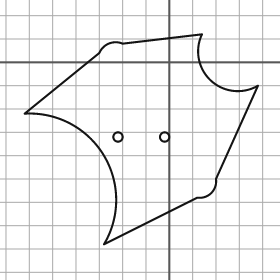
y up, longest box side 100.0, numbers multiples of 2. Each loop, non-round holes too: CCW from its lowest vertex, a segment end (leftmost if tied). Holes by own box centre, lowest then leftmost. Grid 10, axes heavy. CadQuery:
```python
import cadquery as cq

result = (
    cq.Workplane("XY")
    .moveTo(-28.0, -78.0)
    .lineTo(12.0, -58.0)
    .threePointArc((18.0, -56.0), (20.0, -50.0))
    .lineTo(38.0, -10.0)
    .threePointArc((18.0, -8.0), (14.0, 12.0))
    .lineTo(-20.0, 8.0)
    .threePointArc((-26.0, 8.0), (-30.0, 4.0))
    .lineTo(-62.0, -22.0)
    .threePointArc((-28.0, -40.0), (-28.0, -78.0))
    .close()
    .moveTo(-22.0, -32.0)
    .circle(2.0)
    .moveTo(-2.0, -32.0)
    .circle(2.0)
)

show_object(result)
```